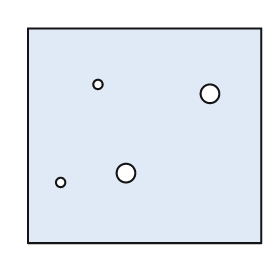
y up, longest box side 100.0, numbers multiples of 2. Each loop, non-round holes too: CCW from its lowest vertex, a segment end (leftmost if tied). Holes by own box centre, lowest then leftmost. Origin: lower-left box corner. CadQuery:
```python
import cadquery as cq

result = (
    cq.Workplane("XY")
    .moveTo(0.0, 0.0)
    .lineTo(100.0, 0.0)
    .lineTo(100.0, 92.0)
    .lineTo(0.0, 92.0)
    .close()
    .moveTo(14.0, 26.0)
    .circle(2.0)
    .moveTo(42.0, 30.0)
    .circle(4.0)
    .moveTo(78.0, 64.0)
    .circle(4.0)
    .moveTo(30.0, 68.0)
    .circle(2.0)
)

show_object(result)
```